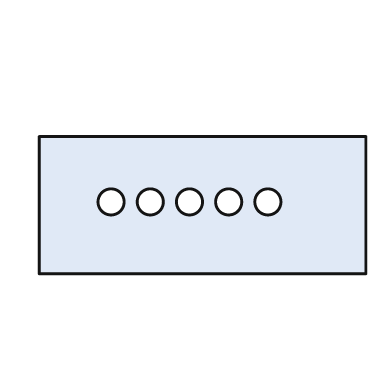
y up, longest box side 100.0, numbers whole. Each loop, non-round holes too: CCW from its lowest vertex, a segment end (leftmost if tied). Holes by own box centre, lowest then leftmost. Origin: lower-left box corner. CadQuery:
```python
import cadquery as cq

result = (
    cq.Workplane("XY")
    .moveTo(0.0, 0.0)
    .lineTo(100.0, 0.0)
    .lineTo(100.0, 42.0)
    .lineTo(0.0, 42.0)
    .close()
    .moveTo(22.0, 22.0)
    .circle(4.0)
    .moveTo(34.0, 22.0)
    .circle(4.0)
    .moveTo(46.0, 22.0)
    .circle(4.0)
    .moveTo(58.0, 22.0)
    .circle(4.0)
    .moveTo(70.0, 22.0)
    .circle(4.0)
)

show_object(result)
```